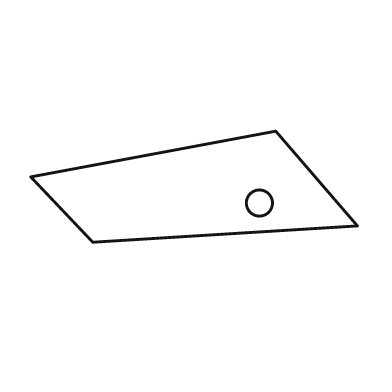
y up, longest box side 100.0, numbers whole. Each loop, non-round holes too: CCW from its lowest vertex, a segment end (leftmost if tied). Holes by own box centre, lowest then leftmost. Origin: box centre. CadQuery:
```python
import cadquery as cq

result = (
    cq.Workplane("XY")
    .moveTo(-31.0, -17.0)
    .lineTo(50.0, -12.0)
    .lineTo(25.0, 17.0)
    .lineTo(-50.0, 3.0)
    .close()
    .moveTo(20.0, -5.0)
    .circle(4.0)
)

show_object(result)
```